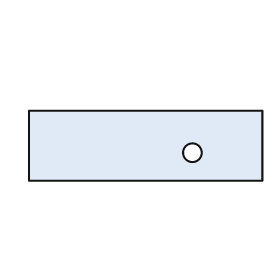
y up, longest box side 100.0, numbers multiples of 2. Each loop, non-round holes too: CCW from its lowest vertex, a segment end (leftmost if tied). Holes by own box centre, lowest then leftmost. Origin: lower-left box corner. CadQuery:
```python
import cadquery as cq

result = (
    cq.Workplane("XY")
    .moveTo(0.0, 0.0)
    .lineTo(100.0, 0.0)
    .lineTo(100.0, 30.0)
    .lineTo(0.0, 30.0)
    .close()
    .moveTo(70.0, 12.0)
    .circle(4.0)
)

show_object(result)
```